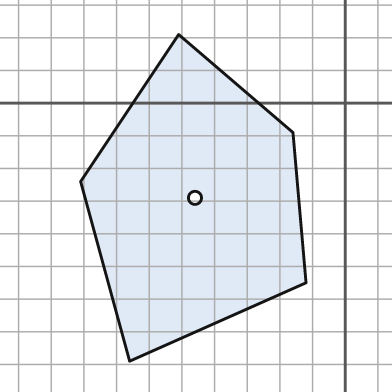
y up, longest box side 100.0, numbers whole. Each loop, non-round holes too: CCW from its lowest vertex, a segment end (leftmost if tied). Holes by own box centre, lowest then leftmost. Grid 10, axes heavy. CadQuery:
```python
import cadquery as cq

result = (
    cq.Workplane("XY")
    .moveTo(-66.0, -79.0)
    .lineTo(-12.0, -55.0)
    .lineTo(-16.0, -9.0)
    .lineTo(-51.0, 21.0)
    .lineTo(-81.0, -24.0)
    .close()
    .moveTo(-46.0, -29.0)
    .circle(2.0)
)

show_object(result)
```